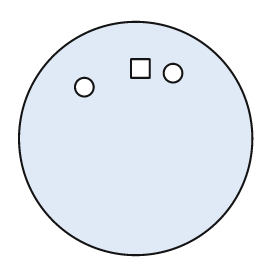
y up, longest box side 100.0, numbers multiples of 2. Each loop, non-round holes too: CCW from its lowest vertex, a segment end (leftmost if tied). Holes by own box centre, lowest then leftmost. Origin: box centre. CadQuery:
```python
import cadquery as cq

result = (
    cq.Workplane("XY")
    .moveTo(0.0, 0.0)
    .circle(50.0)
    .moveTo(-22.0, 22.0)
    .circle(4.0)
    .moveTo(16.0, 28.0)
    .circle(4.0)
    .moveTo(-2.0, 26.0)
    .lineTo(6.0, 26.0)
    .lineTo(6.0, 34.0)
    .lineTo(-2.0, 34.0)
    .close()
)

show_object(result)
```